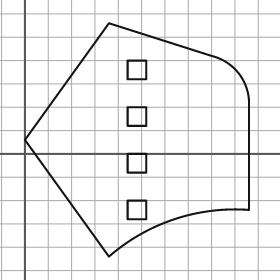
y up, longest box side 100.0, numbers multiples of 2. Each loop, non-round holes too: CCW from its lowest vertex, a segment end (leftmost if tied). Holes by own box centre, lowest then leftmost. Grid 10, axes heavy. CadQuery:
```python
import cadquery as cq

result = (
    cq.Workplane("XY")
    .moveTo(36.0, -44.0)
    .threePointArc((64.0, -28.0), (96.0, -24.0))
    .lineTo(96.0, 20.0)
    .threePointArc((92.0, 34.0), (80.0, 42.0))
    .lineTo(36.0, 56.0)
    .lineTo(0.0, 6.0)
    .close()
    .moveTo(44.0, -28.0)
    .lineTo(52.0, -28.0)
    .lineTo(52.0, -20.0)
    .lineTo(44.0, -20.0)
    .close()
    .moveTo(44.0, -8.0)
    .lineTo(52.0, -8.0)
    .lineTo(52.0, 0.0)
    .lineTo(44.0, 0.0)
    .close()
    .moveTo(44.0, 12.0)
    .lineTo(52.0, 12.0)
    .lineTo(52.0, 20.0)
    .lineTo(44.0, 20.0)
    .close()
    .moveTo(44.0, 32.0)
    .lineTo(52.0, 32.0)
    .lineTo(52.0, 40.0)
    .lineTo(44.0, 40.0)
    .close()
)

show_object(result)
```